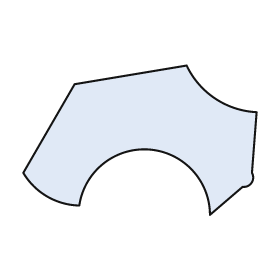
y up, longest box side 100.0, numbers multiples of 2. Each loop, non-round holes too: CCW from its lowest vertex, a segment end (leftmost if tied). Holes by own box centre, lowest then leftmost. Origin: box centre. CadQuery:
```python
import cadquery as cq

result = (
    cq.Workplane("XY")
    .moveTo(30.0, -32.0)
    .lineTo(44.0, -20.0)
    .threePointArc((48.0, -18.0), (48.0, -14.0))
    .lineTo(50.0, 12.0)
    .threePointArc((32.0, 18.0), (20.0, 32.0))
    .lineTo(-28.0, 24.0)
    .lineTo(-50.0, -14.0)
    .threePointArc((-40.0, -24.0), (-26.0, -28.0))
    .threePointArc((4.0, -4.0), (30.0, -32.0))
    .close()
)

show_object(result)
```